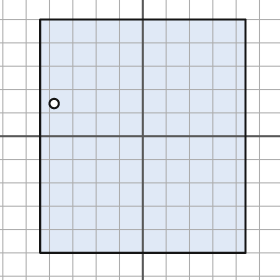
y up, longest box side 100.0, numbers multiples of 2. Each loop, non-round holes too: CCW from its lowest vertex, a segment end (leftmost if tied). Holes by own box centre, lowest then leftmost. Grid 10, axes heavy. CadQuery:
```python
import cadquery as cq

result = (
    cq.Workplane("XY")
    .moveTo(-44.0, -50.0)
    .lineTo(44.0, -50.0)
    .lineTo(44.0, 50.0)
    .lineTo(-44.0, 50.0)
    .close()
    .moveTo(-38.0, 14.0)
    .circle(2.0)
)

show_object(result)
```